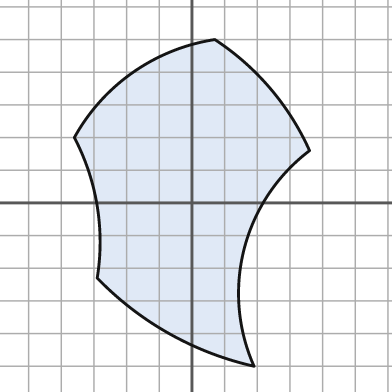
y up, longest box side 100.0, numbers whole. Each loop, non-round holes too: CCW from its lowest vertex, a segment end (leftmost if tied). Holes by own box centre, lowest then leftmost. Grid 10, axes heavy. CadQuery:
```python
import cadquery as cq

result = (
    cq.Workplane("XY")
    .moveTo(19.0, -50.0)
    .threePointArc((16.0, -14.0), (36.0, 16.0))
    .threePointArc((24.0, 35.0), (7.0, 50.0))
    .threePointArc((-18.0, 40.0), (-36.0, 20.0))
    .threePointArc((-29.0, -1.0), (-29.0, -23.0))
    .threePointArc((-7.0, -40.0), (19.0, -50.0))
    .close()
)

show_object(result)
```